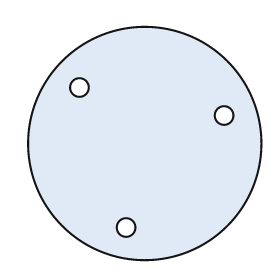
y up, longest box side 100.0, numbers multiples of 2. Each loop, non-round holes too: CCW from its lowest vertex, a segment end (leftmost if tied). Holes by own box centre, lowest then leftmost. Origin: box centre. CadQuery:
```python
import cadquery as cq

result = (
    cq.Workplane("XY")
    .moveTo(0.0, 0.0)
    .circle(50.0)
    .moveTo(-8.0, -36.0)
    .circle(4.0)
    .moveTo(34.0, 12.0)
    .circle(4.0)
    .moveTo(-28.0, 24.0)
    .circle(4.0)
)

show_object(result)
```